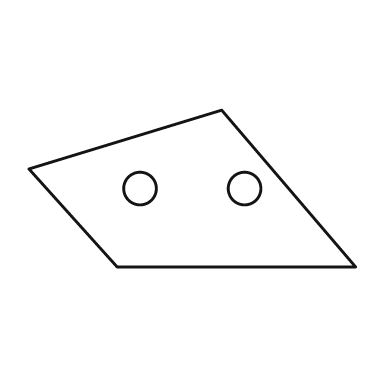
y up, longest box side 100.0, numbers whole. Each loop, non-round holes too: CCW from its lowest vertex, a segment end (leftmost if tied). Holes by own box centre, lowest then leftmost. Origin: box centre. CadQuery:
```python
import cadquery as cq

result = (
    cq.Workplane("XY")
    .moveTo(-23.0, -24.0)
    .lineTo(50.0, -24.0)
    .lineTo(9.0, 24.0)
    .lineTo(-50.0, 6.0)
    .close()
    .moveTo(-16.0, 0.0)
    .circle(5.0)
    .moveTo(16.0, 0.0)
    .circle(5.0)
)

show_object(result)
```